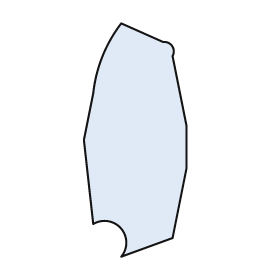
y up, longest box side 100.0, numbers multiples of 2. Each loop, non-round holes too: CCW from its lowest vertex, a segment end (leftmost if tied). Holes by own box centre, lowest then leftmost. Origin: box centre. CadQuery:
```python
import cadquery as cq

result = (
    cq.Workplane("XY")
    .moveTo(-6.0, -50.0)
    .lineTo(16.0, -42.0)
    .lineTo(22.0, -12.0)
    .lineTo(22.0, 6.0)
    .lineTo(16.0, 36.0)
    .threePointArc((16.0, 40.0), (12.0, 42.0))
    .lineTo(-6.0, 50.0)
    .threePointArc((-14.0, 36.0), (-18.0, 20.0))
    .lineTo(-22.0, 0.0)
    .lineTo(-18.0, -36.0)
    .threePointArc((-6.0, -38.0), (-6.0, -50.0))
    .close()
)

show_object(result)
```